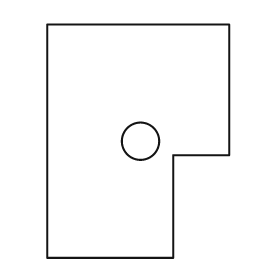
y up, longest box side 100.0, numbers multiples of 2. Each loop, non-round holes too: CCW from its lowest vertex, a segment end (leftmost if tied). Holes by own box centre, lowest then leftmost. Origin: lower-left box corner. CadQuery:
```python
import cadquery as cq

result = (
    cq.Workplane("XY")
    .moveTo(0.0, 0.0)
    .lineTo(54.0, 0.0)
    .lineTo(54.0, 44.0)
    .lineTo(78.0, 44.0)
    .lineTo(78.0, 100.0)
    .lineTo(0.0, 100.0)
    .close()
    .moveTo(40.0, 50.0)
    .circle(8.0)
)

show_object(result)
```